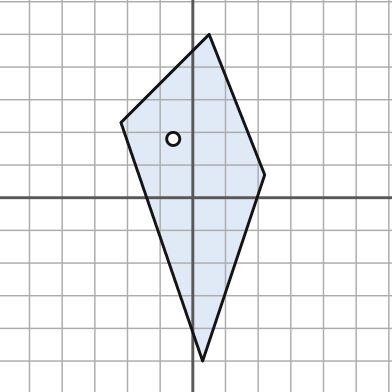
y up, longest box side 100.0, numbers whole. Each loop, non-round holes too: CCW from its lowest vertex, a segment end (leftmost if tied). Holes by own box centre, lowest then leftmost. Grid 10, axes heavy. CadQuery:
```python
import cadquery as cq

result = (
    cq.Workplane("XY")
    .moveTo(3.0, -50.0)
    .lineTo(22.0, 7.0)
    .lineTo(5.0, 50.0)
    .lineTo(-22.0, 23.0)
    .close()
    .moveTo(-6.0, 18.0)
    .circle(2.0)
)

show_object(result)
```